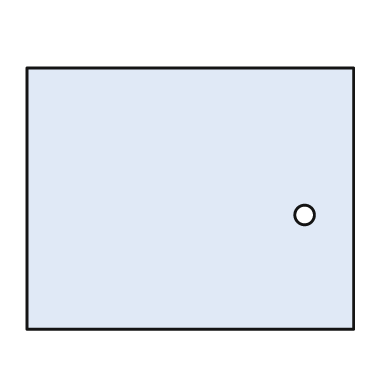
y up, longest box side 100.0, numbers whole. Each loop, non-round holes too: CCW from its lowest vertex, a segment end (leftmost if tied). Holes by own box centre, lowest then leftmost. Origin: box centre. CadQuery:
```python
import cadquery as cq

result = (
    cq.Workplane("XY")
    .moveTo(-50.0, -40.0)
    .lineTo(50.0, -40.0)
    .lineTo(50.0, 40.0)
    .lineTo(-50.0, 40.0)
    .close()
    .moveTo(35.0, -5.0)
    .circle(3.0)
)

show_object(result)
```